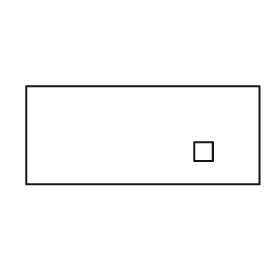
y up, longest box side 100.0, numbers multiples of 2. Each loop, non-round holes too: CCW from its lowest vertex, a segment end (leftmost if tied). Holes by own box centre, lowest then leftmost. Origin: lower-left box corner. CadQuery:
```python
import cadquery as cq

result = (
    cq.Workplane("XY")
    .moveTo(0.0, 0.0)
    .lineTo(100.0, 0.0)
    .lineTo(100.0, 42.0)
    .lineTo(0.0, 42.0)
    .close()
    .moveTo(72.0, 10.0)
    .lineTo(80.0, 10.0)
    .lineTo(80.0, 18.0)
    .lineTo(72.0, 18.0)
    .close()
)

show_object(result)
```